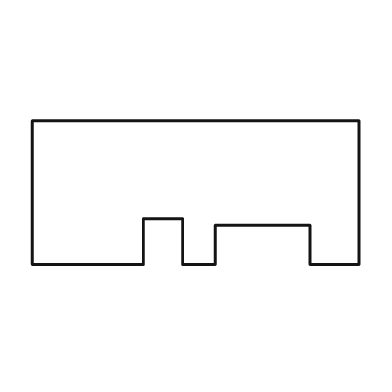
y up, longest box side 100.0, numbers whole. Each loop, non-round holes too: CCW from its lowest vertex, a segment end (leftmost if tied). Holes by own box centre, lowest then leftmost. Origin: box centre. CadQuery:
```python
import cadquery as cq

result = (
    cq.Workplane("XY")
    .moveTo(-50.0, -22.0)
    .lineTo(-16.0, -22.0)
    .lineTo(-16.0, -8.0)
    .lineTo(-4.0, -8.0)
    .lineTo(-4.0, -22.0)
    .lineTo(6.0, -22.0)
    .lineTo(6.0, -10.0)
    .lineTo(35.0, -10.0)
    .lineTo(35.0, -22.0)
    .lineTo(50.0, -22.0)
    .lineTo(50.0, 22.0)
    .lineTo(-50.0, 22.0)
    .close()
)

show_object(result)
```